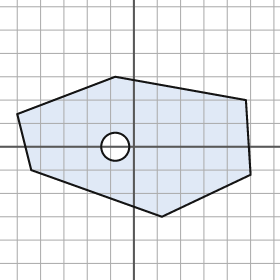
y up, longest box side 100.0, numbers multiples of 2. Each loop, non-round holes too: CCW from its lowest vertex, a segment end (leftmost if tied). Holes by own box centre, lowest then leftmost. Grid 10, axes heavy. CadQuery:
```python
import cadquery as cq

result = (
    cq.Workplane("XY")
    .moveTo(12.0, -30.0)
    .lineTo(50.0, -12.0)
    .lineTo(48.0, 20.0)
    .lineTo(-8.0, 30.0)
    .lineTo(-50.0, 14.0)
    .lineTo(-44.0, -10.0)
    .close()
    .moveTo(-8.0, 0.0)
    .circle(6.0)
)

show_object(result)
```